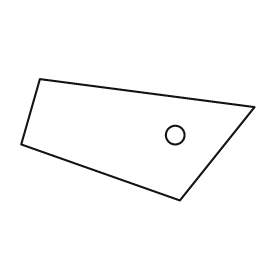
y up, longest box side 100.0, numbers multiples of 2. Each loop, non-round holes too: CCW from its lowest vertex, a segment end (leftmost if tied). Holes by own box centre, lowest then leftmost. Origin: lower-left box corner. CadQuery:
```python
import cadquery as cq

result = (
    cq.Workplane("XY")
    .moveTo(68.0, 0.0)
    .lineTo(100.0, 40.0)
    .lineTo(8.0, 52.0)
    .lineTo(0.0, 24.0)
    .close()
    .moveTo(66.0, 28.0)
    .circle(4.0)
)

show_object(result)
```